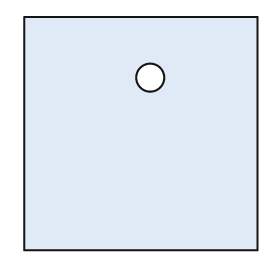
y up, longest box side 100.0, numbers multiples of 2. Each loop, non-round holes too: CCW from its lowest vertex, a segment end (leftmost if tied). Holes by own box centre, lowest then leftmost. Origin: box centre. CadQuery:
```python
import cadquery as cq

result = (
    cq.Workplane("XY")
    .moveTo(-50.0, -50.0)
    .lineTo(50.0, -50.0)
    .lineTo(50.0, 50.0)
    .lineTo(-50.0, 50.0)
    .close()
    .moveTo(4.0, 24.0)
    .circle(6.0)
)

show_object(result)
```